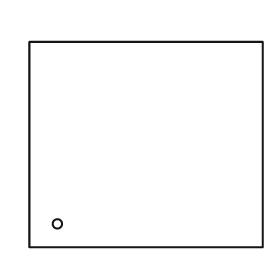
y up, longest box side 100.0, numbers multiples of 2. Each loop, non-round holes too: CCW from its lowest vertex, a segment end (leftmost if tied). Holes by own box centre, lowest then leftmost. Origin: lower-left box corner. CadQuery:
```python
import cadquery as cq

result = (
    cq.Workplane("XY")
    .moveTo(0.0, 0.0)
    .lineTo(100.0, 0.0)
    .lineTo(100.0, 88.0)
    .lineTo(0.0, 88.0)
    .close()
    .moveTo(12.0, 10.0)
    .circle(2.0)
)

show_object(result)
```